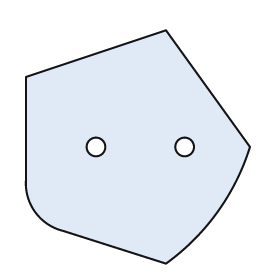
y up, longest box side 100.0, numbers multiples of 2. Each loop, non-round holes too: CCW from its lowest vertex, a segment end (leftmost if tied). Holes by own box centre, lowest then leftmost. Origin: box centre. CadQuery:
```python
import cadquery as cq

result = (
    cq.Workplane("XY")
    .moveTo(12.0, -50.0)
    .threePointArc((34.0, -28.0), (48.0, 0.0))
    .lineTo(12.0, 50.0)
    .lineTo(-48.0, 30.0)
    .lineTo(-48.0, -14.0)
    .threePointArc((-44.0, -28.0), (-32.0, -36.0))
    .close()
    .moveTo(-18.0, 0.0)
    .circle(4.0)
    .moveTo(20.0, 0.0)
    .circle(4.0)
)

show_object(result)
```